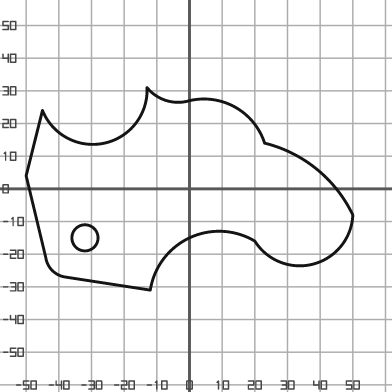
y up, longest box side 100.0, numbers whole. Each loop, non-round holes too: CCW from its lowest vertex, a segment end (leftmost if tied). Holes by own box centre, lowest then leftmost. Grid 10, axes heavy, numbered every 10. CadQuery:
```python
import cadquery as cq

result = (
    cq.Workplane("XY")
    .moveTo(-12.0, -31.0)
    .threePointArc((0.0, -15.0), (20.0, -16.0))
    .threePointArc((38.0, -23.0), (50.0, -8.0))
    .threePointArc((39.0, 6.0), (23.0, 14.0))
    .threePointArc((14.0, 25.0), (0.0, 27.0))
    .threePointArc((-7.0, 27.0), (-13.0, 31.0))
    .threePointArc((-26.0, 14.0), (-45.0, 24.0))
    .lineTo(-50.0, 4.0)
    .lineTo(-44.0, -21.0)
    .threePointArc((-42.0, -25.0), (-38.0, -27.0))
    .close()
    .moveTo(-32.0, -15.0)
    .circle(4.0)
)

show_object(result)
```